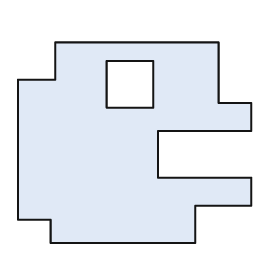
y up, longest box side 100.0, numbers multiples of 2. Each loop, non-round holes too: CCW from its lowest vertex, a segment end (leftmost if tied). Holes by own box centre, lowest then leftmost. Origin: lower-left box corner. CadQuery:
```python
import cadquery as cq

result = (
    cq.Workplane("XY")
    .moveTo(14.0, 0.0)
    .lineTo(76.0, 0.0)
    .lineTo(76.0, 16.0)
    .lineTo(100.0, 16.0)
    .lineTo(100.0, 28.0)
    .lineTo(60.0, 28.0)
    .lineTo(60.0, 48.0)
    .lineTo(100.0, 48.0)
    .lineTo(100.0, 60.0)
    .lineTo(86.0, 60.0)
    .lineTo(86.0, 86.0)
    .lineTo(16.0, 86.0)
    .lineTo(16.0, 70.0)
    .lineTo(0.0, 70.0)
    .lineTo(0.0, 10.0)
    .lineTo(14.0, 10.0)
    .close()
    .moveTo(38.0, 58.0)
    .lineTo(58.0, 58.0)
    .lineTo(58.0, 78.0)
    .lineTo(38.0, 78.0)
    .close()
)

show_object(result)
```